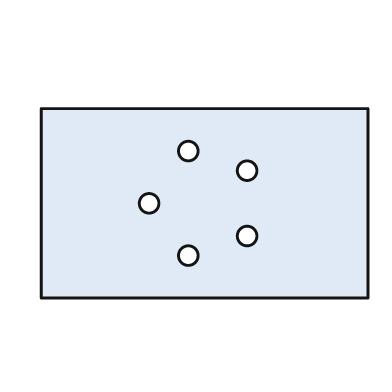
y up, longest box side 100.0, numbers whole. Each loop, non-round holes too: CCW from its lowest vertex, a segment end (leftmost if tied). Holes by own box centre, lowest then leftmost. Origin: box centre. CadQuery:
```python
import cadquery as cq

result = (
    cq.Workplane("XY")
    .moveTo(-50.0, -29.0)
    .lineTo(50.0, -29.0)
    .lineTo(50.0, 29.0)
    .lineTo(-50.0, 29.0)
    .close()
    .moveTo(-5.0, -16.0)
    .circle(3.0)
    .moveTo(13.0, -10.0)
    .circle(3.0)
    .moveTo(-17.0, 0.0)
    .circle(3.0)
    .moveTo(13.0, 10.0)
    .circle(3.0)
    .moveTo(-5.0, 16.0)
    .circle(3.0)
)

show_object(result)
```